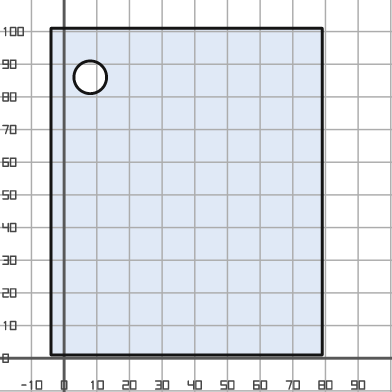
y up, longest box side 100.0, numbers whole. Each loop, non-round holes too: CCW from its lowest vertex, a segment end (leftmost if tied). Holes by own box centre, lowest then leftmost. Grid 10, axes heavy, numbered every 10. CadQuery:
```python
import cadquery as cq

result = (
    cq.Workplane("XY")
    .moveTo(-4.0, 1.0)
    .lineTo(79.0, 1.0)
    .lineTo(79.0, 101.0)
    .lineTo(-4.0, 101.0)
    .close()
    .moveTo(8.0, 86.0)
    .circle(5.0)
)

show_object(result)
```